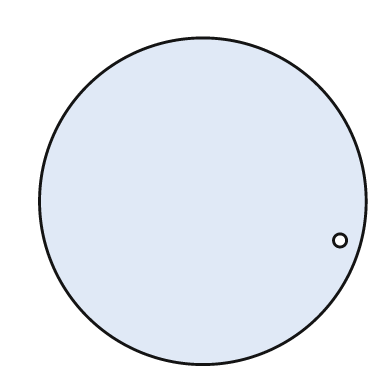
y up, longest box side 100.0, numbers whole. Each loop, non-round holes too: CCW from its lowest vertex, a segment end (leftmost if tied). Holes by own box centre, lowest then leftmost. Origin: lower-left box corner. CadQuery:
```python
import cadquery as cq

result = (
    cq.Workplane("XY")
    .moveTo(50.0, 50.0)
    .circle(50.0)
    .moveTo(92.0, 38.0)
    .circle(2.0)
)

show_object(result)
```